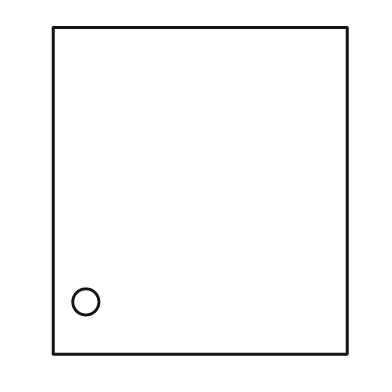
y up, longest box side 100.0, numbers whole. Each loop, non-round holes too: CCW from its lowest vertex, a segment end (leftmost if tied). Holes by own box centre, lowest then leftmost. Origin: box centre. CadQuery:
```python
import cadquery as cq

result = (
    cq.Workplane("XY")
    .moveTo(-45.0, -50.0)
    .lineTo(45.0, -50.0)
    .lineTo(45.0, 50.0)
    .lineTo(-45.0, 50.0)
    .close()
    .moveTo(-35.0, -34.0)
    .circle(4.0)
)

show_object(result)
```